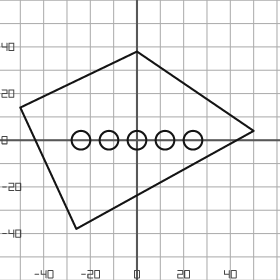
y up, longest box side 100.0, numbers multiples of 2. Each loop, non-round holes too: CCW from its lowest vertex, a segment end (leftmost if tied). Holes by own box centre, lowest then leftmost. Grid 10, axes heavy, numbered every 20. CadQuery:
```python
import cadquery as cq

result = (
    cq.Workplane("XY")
    .moveTo(-26.0, -38.0)
    .lineTo(50.0, 4.0)
    .lineTo(0.0, 38.0)
    .lineTo(-50.0, 14.0)
    .close()
    .moveTo(-24.0, 0.0)
    .circle(4.0)
    .moveTo(-12.0, 0.0)
    .circle(4.0)
    .moveTo(0.0, 0.0)
    .circle(4.0)
    .moveTo(12.0, 0.0)
    .circle(4.0)
    .moveTo(24.0, 0.0)
    .circle(4.0)
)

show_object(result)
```